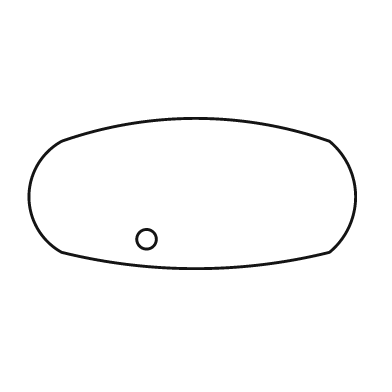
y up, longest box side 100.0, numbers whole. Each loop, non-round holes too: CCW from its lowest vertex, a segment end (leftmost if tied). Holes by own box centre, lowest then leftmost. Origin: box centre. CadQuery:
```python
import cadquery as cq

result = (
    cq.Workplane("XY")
    .moveTo(-40.0, -18.0)
    .threePointArc((1.0, -23.0), (42.0, -18.0))
    .threePointArc((50.0, -1.0), (42.0, 16.0))
    .threePointArc((1.0, 23.0), (-40.0, 16.0))
    .threePointArc((-50.0, -1.0), (-40.0, -18.0))
    .close()
    .moveTo(-14.0, -14.0)
    .circle(3.0)
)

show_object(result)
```